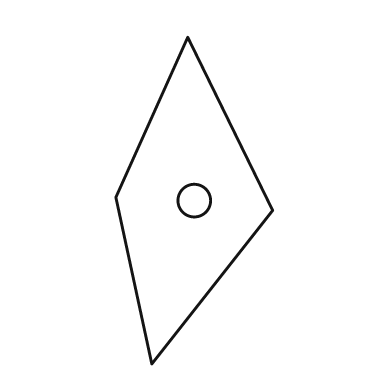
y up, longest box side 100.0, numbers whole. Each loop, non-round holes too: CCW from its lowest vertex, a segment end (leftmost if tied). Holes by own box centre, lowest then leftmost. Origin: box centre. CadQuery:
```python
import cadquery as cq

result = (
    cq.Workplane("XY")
    .moveTo(-13.0, -50.0)
    .lineTo(24.0, -3.0)
    .lineTo(-2.0, 50.0)
    .lineTo(-24.0, 1.0)
    .close()
    .moveTo(0.0, 0.0)
    .circle(5.0)
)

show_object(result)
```